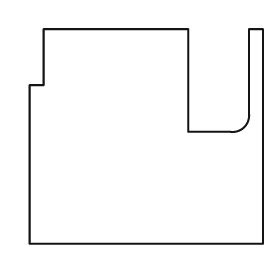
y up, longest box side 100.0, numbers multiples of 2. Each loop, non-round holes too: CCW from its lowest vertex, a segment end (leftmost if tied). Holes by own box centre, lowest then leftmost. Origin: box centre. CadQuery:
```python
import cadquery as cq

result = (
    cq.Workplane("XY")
    .moveTo(-50.0, -46.0)
    .lineTo(50.0, -46.0)
    .lineTo(50.0, 46.0)
    .lineTo(44.0, 46.0)
    .lineTo(44.0, 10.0)
    .threePointArc((42.0, 4.0), (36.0, 2.0))
    .lineTo(18.0, 2.0)
    .lineTo(18.0, 46.0)
    .lineTo(-44.0, 46.0)
    .lineTo(-44.0, 22.0)
    .lineTo(-50.0, 22.0)
    .close()
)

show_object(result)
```